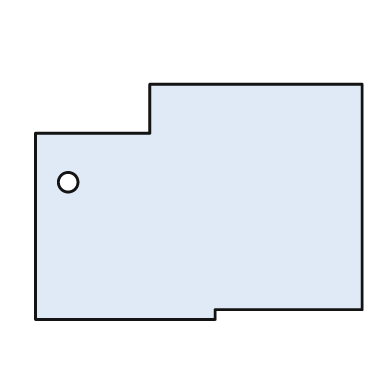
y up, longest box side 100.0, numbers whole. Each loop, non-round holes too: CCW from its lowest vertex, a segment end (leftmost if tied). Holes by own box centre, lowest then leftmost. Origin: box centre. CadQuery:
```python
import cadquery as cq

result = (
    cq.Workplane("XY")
    .moveTo(-50.0, -36.0)
    .lineTo(5.0, -36.0)
    .lineTo(5.0, -33.0)
    .lineTo(50.0, -33.0)
    .lineTo(50.0, 36.0)
    .lineTo(-15.0, 36.0)
    .lineTo(-15.0, 21.0)
    .lineTo(-50.0, 21.0)
    .close()
    .moveTo(-40.0, 6.0)
    .circle(3.0)
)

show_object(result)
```